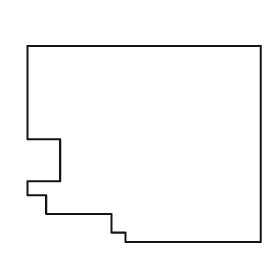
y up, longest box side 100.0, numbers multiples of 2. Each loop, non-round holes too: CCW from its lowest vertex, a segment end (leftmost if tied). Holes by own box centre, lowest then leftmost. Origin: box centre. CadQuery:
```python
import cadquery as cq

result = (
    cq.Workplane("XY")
    .moveTo(-8.0, -42.0)
    .lineTo(50.0, -42.0)
    .lineTo(50.0, 42.0)
    .lineTo(-50.0, 42.0)
    .lineTo(-50.0, 2.0)
    .lineTo(-36.0, 2.0)
    .lineTo(-36.0, -16.0)
    .lineTo(-50.0, -16.0)
    .lineTo(-50.0, -22.0)
    .lineTo(-42.0, -22.0)
    .lineTo(-42.0, -30.0)
    .lineTo(-14.0, -30.0)
    .lineTo(-14.0, -38.0)
    .lineTo(-8.0, -38.0)
    .close()
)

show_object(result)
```